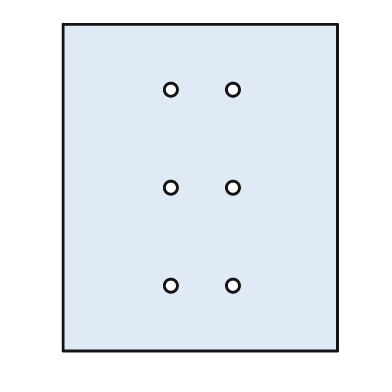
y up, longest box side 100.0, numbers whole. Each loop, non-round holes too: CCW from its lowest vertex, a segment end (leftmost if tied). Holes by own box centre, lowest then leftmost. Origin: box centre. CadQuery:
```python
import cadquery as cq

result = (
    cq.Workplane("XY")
    .moveTo(-42.0, -50.0)
    .lineTo(42.0, -50.0)
    .lineTo(42.0, 50.0)
    .lineTo(-42.0, 50.0)
    .close()
    .moveTo(-9.0, -30.0)
    .circle(2.0)
    .moveTo(10.0, -30.0)
    .circle(2.0)
    .moveTo(-9.0, 0.0)
    .circle(2.0)
    .moveTo(10.0, 0.0)
    .circle(2.0)
    .moveTo(-9.0, 30.0)
    .circle(2.0)
    .moveTo(10.0, 30.0)
    .circle(2.0)
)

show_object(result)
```